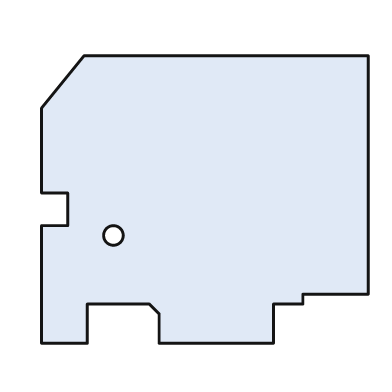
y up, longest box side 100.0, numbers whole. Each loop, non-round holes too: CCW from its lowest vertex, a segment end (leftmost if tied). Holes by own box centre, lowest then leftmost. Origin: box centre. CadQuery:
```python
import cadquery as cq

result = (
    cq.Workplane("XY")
    .moveTo(-50.0, -44.0)
    .lineTo(-36.0, -44.0)
    .lineTo(-36.0, -32.0)
    .lineTo(-17.0, -32.0)
    .lineTo(-14.0, -35.0)
    .lineTo(-14.0, -44.0)
    .lineTo(21.0, -44.0)
    .lineTo(21.0, -32.0)
    .lineTo(30.0, -32.0)
    .lineTo(30.0, -29.0)
    .lineTo(50.0, -29.0)
    .lineTo(50.0, 44.0)
    .lineTo(-37.0, 44.0)
    .lineTo(-50.0, 28.0)
    .lineTo(-50.0, 2.0)
    .lineTo(-42.0, 2.0)
    .lineTo(-42.0, -8.0)
    .lineTo(-50.0, -8.0)
    .close()
    .moveTo(-28.0, -11.0)
    .circle(3.0)
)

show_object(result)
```